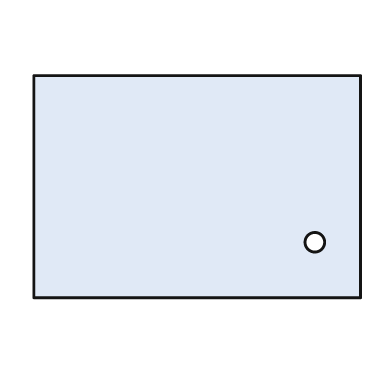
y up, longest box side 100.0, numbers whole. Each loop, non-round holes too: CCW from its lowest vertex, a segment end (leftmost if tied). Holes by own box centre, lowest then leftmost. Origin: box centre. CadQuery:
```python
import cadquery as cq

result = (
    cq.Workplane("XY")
    .moveTo(-50.0, -34.0)
    .lineTo(50.0, -34.0)
    .lineTo(50.0, 34.0)
    .lineTo(-50.0, 34.0)
    .close()
    .moveTo(36.0, -17.0)
    .circle(3.0)
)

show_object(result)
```